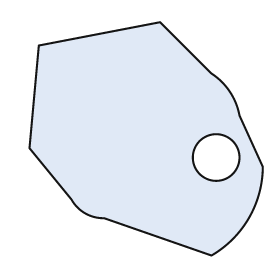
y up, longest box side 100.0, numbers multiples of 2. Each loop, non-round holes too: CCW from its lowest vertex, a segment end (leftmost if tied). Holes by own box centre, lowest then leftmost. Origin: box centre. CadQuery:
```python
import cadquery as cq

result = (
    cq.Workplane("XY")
    .moveTo(28.0, -50.0)
    .threePointArc((44.0, -34.0), (50.0, -12.0))
    .lineTo(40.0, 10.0)
    .threePointArc((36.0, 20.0), (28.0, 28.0))
    .lineTo(6.0, 50.0)
    .lineTo(-46.0, 40.0)
    .lineTo(-50.0, -4.0)
    .lineTo(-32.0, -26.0)
    .threePointArc((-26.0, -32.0), (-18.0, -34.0))
    .close()
    .moveTo(30.0, -8.0)
    .circle(10.0)
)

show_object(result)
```